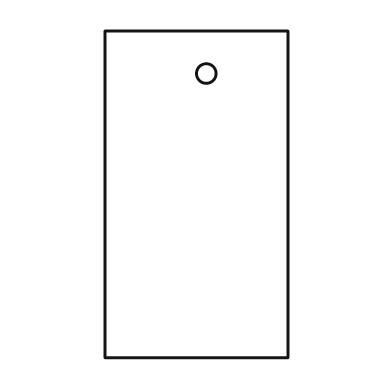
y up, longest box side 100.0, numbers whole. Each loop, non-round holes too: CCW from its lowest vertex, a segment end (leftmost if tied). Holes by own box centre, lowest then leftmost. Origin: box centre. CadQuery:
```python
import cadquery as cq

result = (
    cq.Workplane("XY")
    .moveTo(-28.0, -50.0)
    .lineTo(28.0, -50.0)
    .lineTo(28.0, 50.0)
    .lineTo(-28.0, 50.0)
    .close()
    .moveTo(3.0, 37.0)
    .circle(3.0)
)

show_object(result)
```